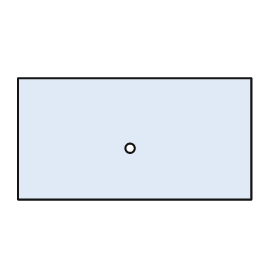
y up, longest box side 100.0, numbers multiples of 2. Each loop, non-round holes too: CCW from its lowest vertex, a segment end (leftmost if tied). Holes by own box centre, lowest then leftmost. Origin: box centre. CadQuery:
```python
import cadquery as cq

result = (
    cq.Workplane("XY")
    .moveTo(-50.0, -26.0)
    .lineTo(50.0, -26.0)
    .lineTo(50.0, 26.0)
    .lineTo(-50.0, 26.0)
    .close()
    .moveTo(-2.0, -4.0)
    .circle(2.0)
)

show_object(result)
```